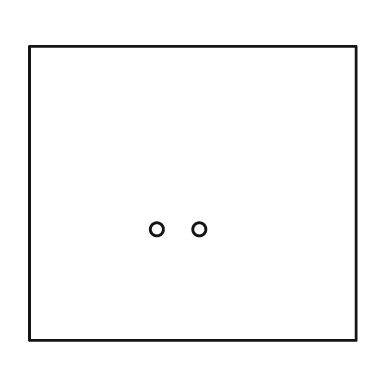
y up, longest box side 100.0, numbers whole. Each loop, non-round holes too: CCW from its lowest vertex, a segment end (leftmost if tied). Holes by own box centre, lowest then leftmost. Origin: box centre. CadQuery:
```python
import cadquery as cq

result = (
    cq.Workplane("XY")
    .moveTo(-50.0, -45.0)
    .lineTo(50.0, -45.0)
    .lineTo(50.0, 45.0)
    .lineTo(-50.0, 45.0)
    .close()
    .moveTo(-11.0, -11.0)
    .circle(2.0)
    .moveTo(2.0, -11.0)
    .circle(2.0)
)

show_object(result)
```